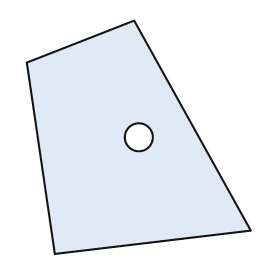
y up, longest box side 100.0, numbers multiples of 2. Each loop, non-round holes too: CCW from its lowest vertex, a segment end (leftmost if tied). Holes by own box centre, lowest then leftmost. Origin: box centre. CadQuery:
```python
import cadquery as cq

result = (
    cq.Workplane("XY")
    .moveTo(-36.0, -50.0)
    .lineTo(48.0, -40.0)
    .lineTo(-2.0, 50.0)
    .lineTo(-48.0, 32.0)
    .close()
    .moveTo(0.0, 0.0)
    .circle(6.0)
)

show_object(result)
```